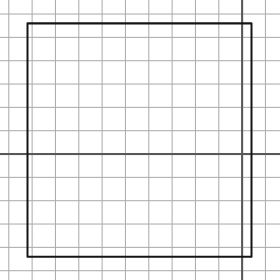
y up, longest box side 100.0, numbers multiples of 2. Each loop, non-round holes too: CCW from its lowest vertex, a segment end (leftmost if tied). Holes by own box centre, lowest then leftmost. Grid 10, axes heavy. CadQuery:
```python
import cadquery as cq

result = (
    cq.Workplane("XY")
    .moveTo(-92.0, -44.0)
    .lineTo(4.0, -44.0)
    .lineTo(4.0, 56.0)
    .lineTo(-92.0, 56.0)
    .close()
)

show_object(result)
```